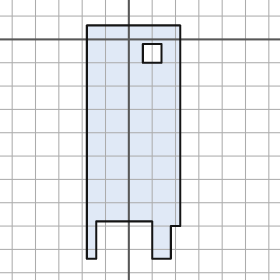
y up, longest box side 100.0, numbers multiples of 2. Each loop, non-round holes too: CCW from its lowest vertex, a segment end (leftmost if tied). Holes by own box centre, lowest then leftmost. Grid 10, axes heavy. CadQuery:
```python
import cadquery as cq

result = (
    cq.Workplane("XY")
    .moveTo(-18.0, -94.0)
    .lineTo(-14.0, -94.0)
    .lineTo(-14.0, -78.0)
    .lineTo(10.0, -78.0)
    .lineTo(10.0, -94.0)
    .lineTo(18.0, -94.0)
    .lineTo(18.0, -80.0)
    .lineTo(22.0, -80.0)
    .lineTo(22.0, 6.0)
    .lineTo(-18.0, 6.0)
    .close()
    .moveTo(6.0, -10.0)
    .lineTo(14.0, -10.0)
    .lineTo(14.0, -2.0)
    .lineTo(6.0, -2.0)
    .close()
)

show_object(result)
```